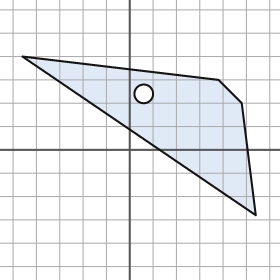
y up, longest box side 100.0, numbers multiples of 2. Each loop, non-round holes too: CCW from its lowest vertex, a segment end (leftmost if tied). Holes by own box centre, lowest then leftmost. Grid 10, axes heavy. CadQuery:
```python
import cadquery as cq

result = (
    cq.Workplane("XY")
    .moveTo(54.0, -28.0)
    .lineTo(48.0, 20.0)
    .lineTo(38.0, 30.0)
    .lineTo(-46.0, 40.0)
    .close()
    .moveTo(6.0, 24.0)
    .circle(4.0)
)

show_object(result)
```